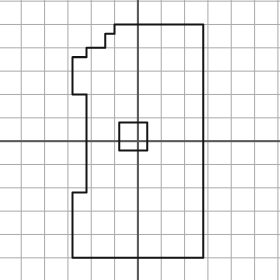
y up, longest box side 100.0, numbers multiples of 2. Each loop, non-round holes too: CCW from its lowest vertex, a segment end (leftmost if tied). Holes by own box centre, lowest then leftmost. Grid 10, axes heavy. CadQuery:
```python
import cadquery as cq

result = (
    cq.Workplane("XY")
    .moveTo(-28.0, -50.0)
    .lineTo(28.0, -50.0)
    .lineTo(28.0, 50.0)
    .lineTo(-10.0, 50.0)
    .lineTo(-10.0, 46.0)
    .lineTo(-14.0, 46.0)
    .lineTo(-14.0, 40.0)
    .lineTo(-22.0, 40.0)
    .lineTo(-22.0, 36.0)
    .lineTo(-28.0, 36.0)
    .lineTo(-28.0, 20.0)
    .lineTo(-22.0, 20.0)
    .lineTo(-22.0, -22.0)
    .lineTo(-28.0, -22.0)
    .close()
    .moveTo(-8.0, -4.0)
    .lineTo(4.0, -4.0)
    .lineTo(4.0, 8.0)
    .lineTo(-8.0, 8.0)
    .close()
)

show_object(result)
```